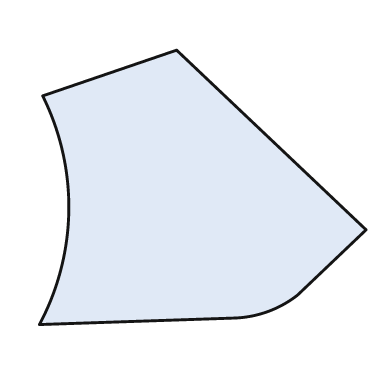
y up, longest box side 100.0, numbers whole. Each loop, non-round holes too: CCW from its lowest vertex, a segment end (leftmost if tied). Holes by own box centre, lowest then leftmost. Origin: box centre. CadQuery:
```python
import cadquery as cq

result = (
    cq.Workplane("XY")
    .moveTo(-50.0, -42.0)
    .lineTo(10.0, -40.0)
    .threePointArc((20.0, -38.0), (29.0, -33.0))
    .lineTo(50.0, -13.0)
    .lineTo(-8.0, 42.0)
    .lineTo(-49.0, 28.0)
    .threePointArc((-41.0, -7.0), (-50.0, -42.0))
    .close()
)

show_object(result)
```